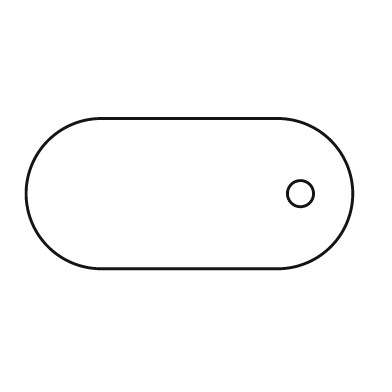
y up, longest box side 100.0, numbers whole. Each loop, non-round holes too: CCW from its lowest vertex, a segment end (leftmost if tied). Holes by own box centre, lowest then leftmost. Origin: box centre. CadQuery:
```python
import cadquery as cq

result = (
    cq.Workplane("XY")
    .moveTo(-27.0, -23.0)
    .lineTo(27.0, -23.0)
    .threePointArc((50.0, 0.0), (27.0, 23.0))
    .lineTo(-27.0, 23.0)
    .threePointArc((-50.0, 0.0), (-27.0, -23.0))
    .close()
    .moveTo(34.0, 0.0)
    .circle(4.0)
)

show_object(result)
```